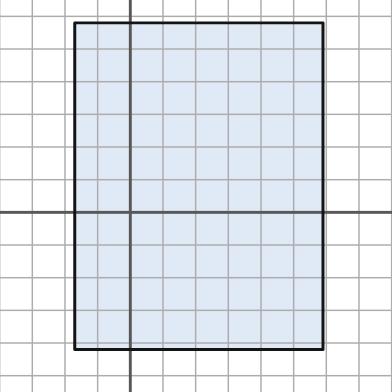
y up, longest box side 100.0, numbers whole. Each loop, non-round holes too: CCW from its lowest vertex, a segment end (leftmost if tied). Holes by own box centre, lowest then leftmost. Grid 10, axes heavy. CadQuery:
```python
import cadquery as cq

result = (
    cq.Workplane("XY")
    .moveTo(-17.0, -42.0)
    .lineTo(59.0, -42.0)
    .lineTo(59.0, 58.0)
    .lineTo(-17.0, 58.0)
    .close()
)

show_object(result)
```